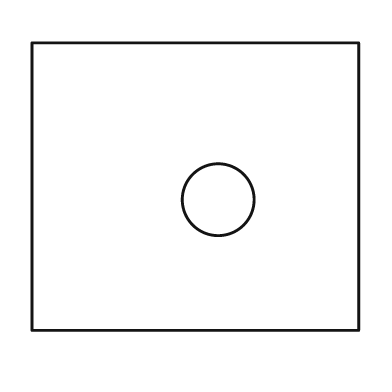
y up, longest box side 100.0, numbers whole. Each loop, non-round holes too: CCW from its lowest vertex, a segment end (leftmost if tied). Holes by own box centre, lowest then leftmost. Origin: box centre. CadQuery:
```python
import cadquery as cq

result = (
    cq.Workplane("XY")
    .moveTo(-50.0, -44.0)
    .lineTo(50.0, -44.0)
    .lineTo(50.0, 44.0)
    .lineTo(-50.0, 44.0)
    .close()
    .moveTo(7.0, -4.0)
    .circle(11.0)
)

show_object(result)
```